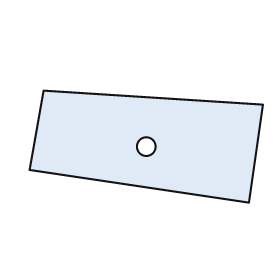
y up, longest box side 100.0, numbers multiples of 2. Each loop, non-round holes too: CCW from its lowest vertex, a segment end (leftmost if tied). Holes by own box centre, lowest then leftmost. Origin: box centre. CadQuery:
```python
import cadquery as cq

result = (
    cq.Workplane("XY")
    .moveTo(44.0, -24.0)
    .lineTo(50.0, 18.0)
    .lineTo(-44.0, 24.0)
    .lineTo(-50.0, -10.0)
    .close()
    .moveTo(0.0, 0.0)
    .circle(4.0)
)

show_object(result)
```